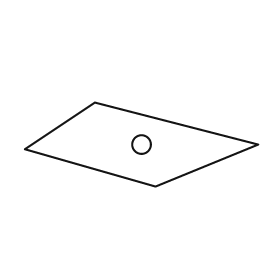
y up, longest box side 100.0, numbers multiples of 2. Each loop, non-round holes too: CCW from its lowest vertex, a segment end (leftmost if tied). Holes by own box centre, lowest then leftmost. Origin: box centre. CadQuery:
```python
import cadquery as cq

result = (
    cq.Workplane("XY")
    .moveTo(6.0, -18.0)
    .lineTo(50.0, 0.0)
    .lineTo(-20.0, 18.0)
    .lineTo(-50.0, -2.0)
    .close()
    .moveTo(0.0, 0.0)
    .circle(4.0)
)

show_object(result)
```